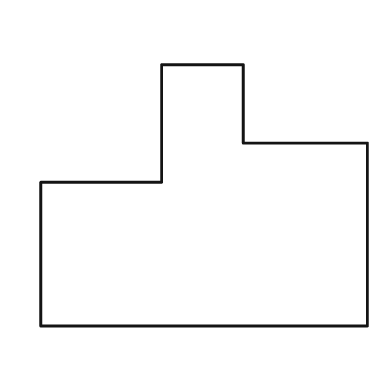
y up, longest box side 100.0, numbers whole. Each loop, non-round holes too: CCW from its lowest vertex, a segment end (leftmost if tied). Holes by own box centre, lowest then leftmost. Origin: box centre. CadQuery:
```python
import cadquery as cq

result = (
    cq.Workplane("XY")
    .moveTo(-50.0, -40.0)
    .lineTo(50.0, -40.0)
    .lineTo(50.0, 16.0)
    .lineTo(12.0, 16.0)
    .lineTo(12.0, 40.0)
    .lineTo(-13.0, 40.0)
    .lineTo(-13.0, 4.0)
    .lineTo(-50.0, 4.0)
    .close()
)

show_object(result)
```